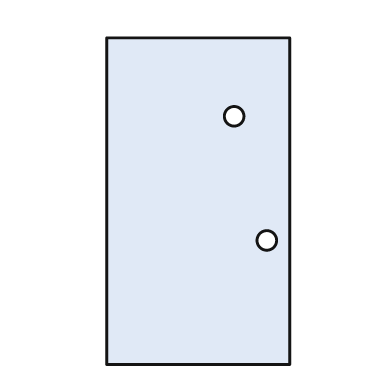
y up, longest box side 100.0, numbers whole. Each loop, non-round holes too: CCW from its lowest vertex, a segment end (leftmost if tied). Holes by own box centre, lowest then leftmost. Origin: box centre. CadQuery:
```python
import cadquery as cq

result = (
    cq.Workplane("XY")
    .moveTo(-28.0, -50.0)
    .lineTo(28.0, -50.0)
    .lineTo(28.0, 50.0)
    .lineTo(-28.0, 50.0)
    .close()
    .moveTo(21.0, -12.0)
    .circle(3.0)
    .moveTo(11.0, 26.0)
    .circle(3.0)
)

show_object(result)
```